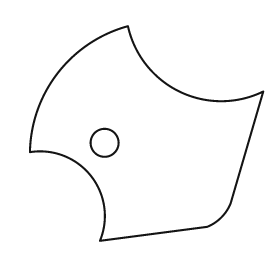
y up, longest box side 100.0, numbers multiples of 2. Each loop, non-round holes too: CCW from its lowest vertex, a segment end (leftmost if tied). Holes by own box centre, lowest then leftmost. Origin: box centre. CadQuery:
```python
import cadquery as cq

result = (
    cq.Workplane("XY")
    .moveTo(-20.0, -46.0)
    .lineTo(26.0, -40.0)
    .threePointArc((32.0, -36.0), (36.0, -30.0))
    .lineTo(50.0, 18.0)
    .threePointArc((14.0, 18.0), (-8.0, 46.0))
    .threePointArc((-38.0, 26.0), (-50.0, -8.0))
    .threePointArc((-24.0, -18.0), (-20.0, -46.0))
    .close()
    .moveTo(-18.0, -4.0)
    .circle(6.0)
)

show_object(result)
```